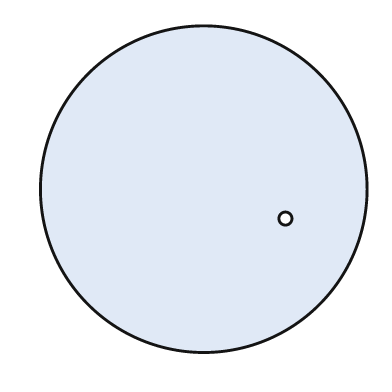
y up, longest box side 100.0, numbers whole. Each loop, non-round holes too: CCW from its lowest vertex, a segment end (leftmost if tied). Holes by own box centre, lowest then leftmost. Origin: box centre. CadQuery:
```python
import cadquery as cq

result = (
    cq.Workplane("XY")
    .moveTo(0.0, 0.0)
    .circle(50.0)
    .moveTo(25.0, -9.0)
    .circle(2.0)
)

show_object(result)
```